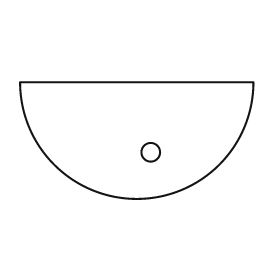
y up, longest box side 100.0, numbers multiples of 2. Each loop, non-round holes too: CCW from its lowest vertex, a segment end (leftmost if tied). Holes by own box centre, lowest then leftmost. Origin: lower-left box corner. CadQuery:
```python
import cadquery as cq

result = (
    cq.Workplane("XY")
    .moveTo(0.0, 50.0)
    .threePointArc((50.0, 0.0), (100.0, 50.0))
    .close()
    .moveTo(56.0, 20.0)
    .circle(4.0)
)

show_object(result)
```